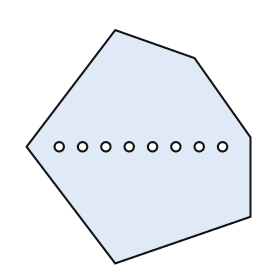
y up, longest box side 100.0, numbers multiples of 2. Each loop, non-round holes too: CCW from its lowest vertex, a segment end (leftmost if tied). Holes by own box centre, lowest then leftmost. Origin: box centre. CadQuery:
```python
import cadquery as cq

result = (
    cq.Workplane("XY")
    .moveTo(-10.0, -50.0)
    .lineTo(48.0, -30.0)
    .lineTo(48.0, 4.0)
    .lineTo(24.0, 38.0)
    .lineTo(-10.0, 50.0)
    .lineTo(-48.0, 0.0)
    .close()
    .moveTo(-34.0, 0.0)
    .circle(2.0)
    .moveTo(-24.0, 0.0)
    .circle(2.0)
    .moveTo(-14.0, 0.0)
    .circle(2.0)
    .moveTo(-4.0, 0.0)
    .circle(2.0)
    .moveTo(6.0, 0.0)
    .circle(2.0)
    .moveTo(16.0, 0.0)
    .circle(2.0)
    .moveTo(26.0, 0.0)
    .circle(2.0)
    .moveTo(36.0, 0.0)
    .circle(2.0)
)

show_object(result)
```